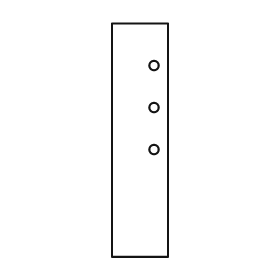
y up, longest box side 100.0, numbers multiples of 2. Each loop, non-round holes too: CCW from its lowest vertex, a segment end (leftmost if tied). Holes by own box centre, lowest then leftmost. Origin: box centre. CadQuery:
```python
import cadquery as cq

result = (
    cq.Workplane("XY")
    .moveTo(-12.0, -50.0)
    .lineTo(12.0, -50.0)
    .lineTo(12.0, 50.0)
    .lineTo(-12.0, 50.0)
    .close()
    .moveTo(6.0, -4.0)
    .circle(2.0)
    .moveTo(6.0, 14.0)
    .circle(2.0)
    .moveTo(6.0, 32.0)
    .circle(2.0)
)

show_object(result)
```